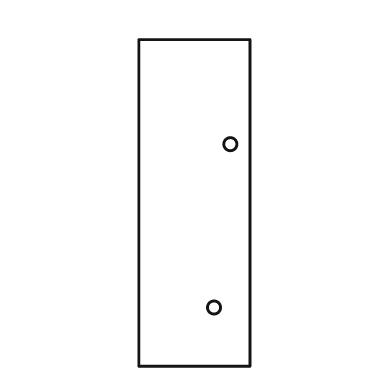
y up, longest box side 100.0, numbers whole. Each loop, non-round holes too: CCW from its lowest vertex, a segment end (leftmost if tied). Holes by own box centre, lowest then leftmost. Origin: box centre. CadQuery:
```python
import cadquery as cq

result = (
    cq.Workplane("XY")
    .moveTo(-17.0, -50.0)
    .lineTo(17.0, -50.0)
    .lineTo(17.0, 50.0)
    .lineTo(-17.0, 50.0)
    .close()
    .moveTo(6.0, -32.0)
    .circle(2.0)
    .moveTo(11.0, 18.0)
    .circle(2.0)
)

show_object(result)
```